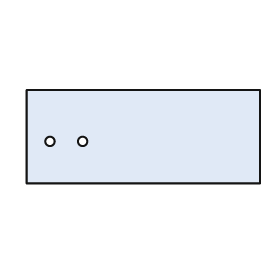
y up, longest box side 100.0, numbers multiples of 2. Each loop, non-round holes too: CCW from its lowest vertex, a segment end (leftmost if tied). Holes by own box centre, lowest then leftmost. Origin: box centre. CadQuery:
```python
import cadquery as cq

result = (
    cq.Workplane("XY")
    .moveTo(-50.0, -20.0)
    .lineTo(50.0, -20.0)
    .lineTo(50.0, 20.0)
    .lineTo(-50.0, 20.0)
    .close()
    .moveTo(-40.0, -2.0)
    .circle(2.0)
    .moveTo(-26.0, -2.0)
    .circle(2.0)
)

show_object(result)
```